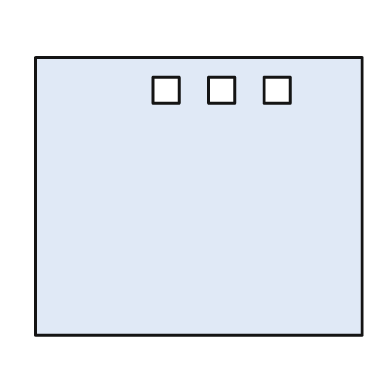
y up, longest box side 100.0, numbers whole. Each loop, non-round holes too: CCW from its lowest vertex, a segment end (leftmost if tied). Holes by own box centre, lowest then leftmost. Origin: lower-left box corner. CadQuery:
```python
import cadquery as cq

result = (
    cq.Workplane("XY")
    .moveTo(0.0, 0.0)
    .lineTo(100.0, 0.0)
    .lineTo(100.0, 85.0)
    .lineTo(0.0, 85.0)
    .close()
    .moveTo(36.0, 71.0)
    .lineTo(44.0, 71.0)
    .lineTo(44.0, 79.0)
    .lineTo(36.0, 79.0)
    .close()
    .moveTo(53.0, 71.0)
    .lineTo(61.0, 71.0)
    .lineTo(61.0, 79.0)
    .lineTo(53.0, 79.0)
    .close()
    .moveTo(70.0, 71.0)
    .lineTo(78.0, 71.0)
    .lineTo(78.0, 79.0)
    .lineTo(70.0, 79.0)
    .close()
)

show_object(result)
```